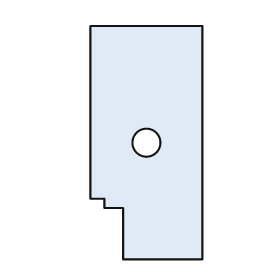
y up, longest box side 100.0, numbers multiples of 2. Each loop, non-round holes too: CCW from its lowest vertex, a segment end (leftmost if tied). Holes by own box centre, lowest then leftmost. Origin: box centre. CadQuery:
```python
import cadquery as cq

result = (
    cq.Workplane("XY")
    .moveTo(-10.0, -50.0)
    .lineTo(24.0, -50.0)
    .lineTo(24.0, 50.0)
    .lineTo(-24.0, 50.0)
    .lineTo(-24.0, -24.0)
    .lineTo(-18.0, -24.0)
    .lineTo(-18.0, -28.0)
    .lineTo(-10.0, -28.0)
    .close()
    .moveTo(0.0, 0.0)
    .circle(6.0)
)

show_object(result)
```